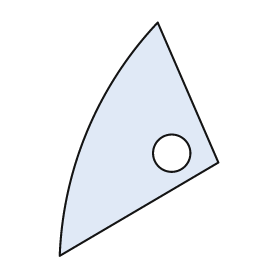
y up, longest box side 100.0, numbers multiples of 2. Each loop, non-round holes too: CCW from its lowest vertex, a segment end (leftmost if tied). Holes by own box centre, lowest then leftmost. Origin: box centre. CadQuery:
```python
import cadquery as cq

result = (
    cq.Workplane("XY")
    .moveTo(-34.0, -50.0)
    .lineTo(34.0, -10.0)
    .lineTo(8.0, 50.0)
    .threePointArc((-22.0, 4.0), (-34.0, -50.0))
    .close()
    .moveTo(14.0, -6.0)
    .circle(8.0)
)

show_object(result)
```